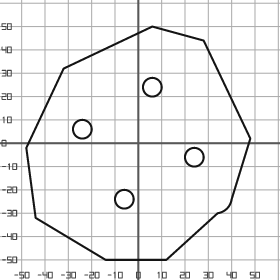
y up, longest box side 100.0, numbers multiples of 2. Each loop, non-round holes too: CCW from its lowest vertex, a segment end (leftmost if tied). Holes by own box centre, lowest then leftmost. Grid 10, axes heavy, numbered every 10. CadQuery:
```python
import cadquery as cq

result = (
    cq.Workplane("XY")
    .moveTo(-14.0, -50.0)
    .lineTo(12.0, -50.0)
    .lineTo(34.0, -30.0)
    .threePointArc((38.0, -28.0), (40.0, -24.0))
    .lineTo(48.0, 2.0)
    .lineTo(28.0, 44.0)
    .lineTo(6.0, 50.0)
    .lineTo(-32.0, 32.0)
    .lineTo(-48.0, -2.0)
    .lineTo(-44.0, -32.0)
    .close()
    .moveTo(-6.0, -24.0)
    .circle(4.0)
    .moveTo(24.0, -6.0)
    .circle(4.0)
    .moveTo(-24.0, 6.0)
    .circle(4.0)
    .moveTo(6.0, 24.0)
    .circle(4.0)
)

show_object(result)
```